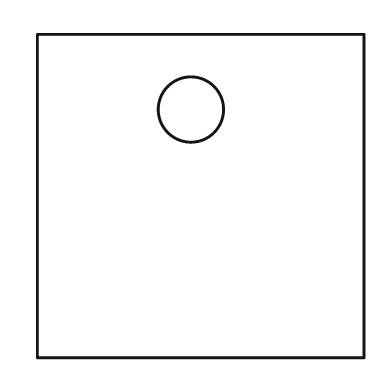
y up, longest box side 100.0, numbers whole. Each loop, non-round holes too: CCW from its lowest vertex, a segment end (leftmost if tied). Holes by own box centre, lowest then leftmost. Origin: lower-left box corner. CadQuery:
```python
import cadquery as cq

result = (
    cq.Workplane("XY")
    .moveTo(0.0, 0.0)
    .lineTo(100.0, 0.0)
    .lineTo(100.0, 99.0)
    .lineTo(0.0, 99.0)
    .close()
    .moveTo(47.0, 76.0)
    .circle(10.0)
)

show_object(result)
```